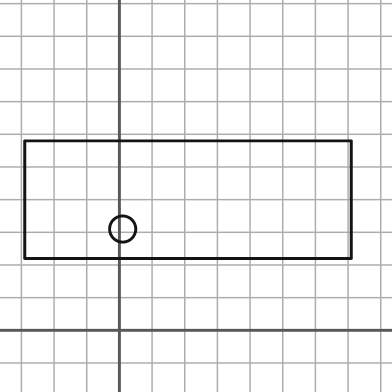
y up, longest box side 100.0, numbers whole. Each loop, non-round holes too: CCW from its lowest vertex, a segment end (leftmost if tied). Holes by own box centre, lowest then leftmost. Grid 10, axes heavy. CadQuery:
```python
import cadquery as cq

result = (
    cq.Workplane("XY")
    .moveTo(-29.0, 22.0)
    .lineTo(71.0, 22.0)
    .lineTo(71.0, 58.0)
    .lineTo(-29.0, 58.0)
    .close()
    .moveTo(1.0, 31.0)
    .circle(4.0)
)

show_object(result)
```